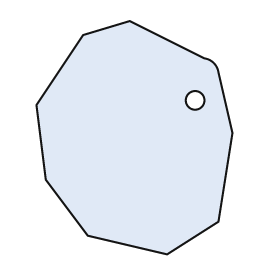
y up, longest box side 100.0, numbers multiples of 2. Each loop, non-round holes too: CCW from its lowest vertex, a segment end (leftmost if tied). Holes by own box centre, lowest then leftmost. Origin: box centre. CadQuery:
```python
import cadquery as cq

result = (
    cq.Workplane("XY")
    .moveTo(14.0, -50.0)
    .lineTo(36.0, -36.0)
    .lineTo(42.0, 2.0)
    .lineTo(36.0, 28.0)
    .threePointArc((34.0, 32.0), (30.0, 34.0))
    .lineTo(-2.0, 50.0)
    .lineTo(-22.0, 44.0)
    .lineTo(-42.0, 14.0)
    .lineTo(-38.0, -18.0)
    .lineTo(-20.0, -42.0)
    .close()
    .moveTo(26.0, 16.0)
    .circle(4.0)
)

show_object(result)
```